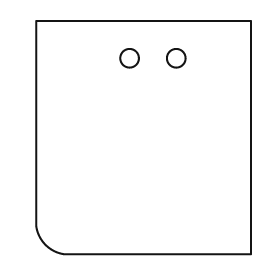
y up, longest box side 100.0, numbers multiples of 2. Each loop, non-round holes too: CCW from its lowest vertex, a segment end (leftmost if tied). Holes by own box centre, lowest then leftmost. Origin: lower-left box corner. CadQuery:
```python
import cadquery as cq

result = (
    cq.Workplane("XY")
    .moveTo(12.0, 0.0)
    .lineTo(92.0, 0.0)
    .lineTo(92.0, 100.0)
    .lineTo(0.0, 100.0)
    .lineTo(0.0, 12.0)
    .threePointArc((4.0, 4.0), (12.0, 0.0))
    .close()
    .moveTo(40.0, 84.0)
    .circle(4.0)
    .moveTo(60.0, 84.0)
    .circle(4.0)
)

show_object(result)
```